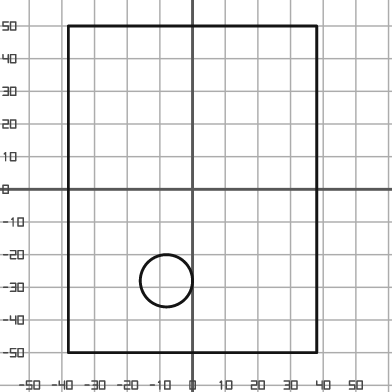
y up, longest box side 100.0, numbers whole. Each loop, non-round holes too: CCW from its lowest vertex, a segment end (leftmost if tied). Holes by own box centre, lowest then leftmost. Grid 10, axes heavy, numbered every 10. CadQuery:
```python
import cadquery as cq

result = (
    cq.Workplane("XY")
    .moveTo(-38.0, -50.0)
    .lineTo(38.0, -50.0)
    .lineTo(38.0, 50.0)
    .lineTo(-38.0, 50.0)
    .close()
    .moveTo(-8.0, -28.0)
    .circle(8.0)
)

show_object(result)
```